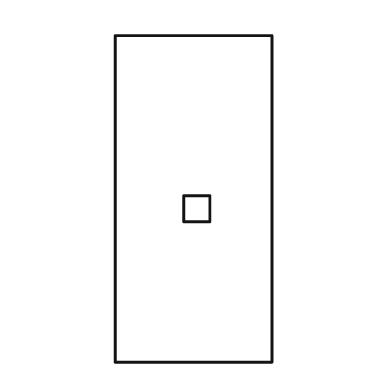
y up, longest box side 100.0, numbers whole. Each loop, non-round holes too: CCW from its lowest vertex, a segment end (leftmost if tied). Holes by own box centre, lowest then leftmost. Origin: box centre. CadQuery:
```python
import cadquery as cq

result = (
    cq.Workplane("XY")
    .moveTo(-24.0, -50.0)
    .lineTo(24.0, -50.0)
    .lineTo(24.0, 50.0)
    .lineTo(-24.0, 50.0)
    .close()
    .moveTo(-3.0, -7.0)
    .lineTo(5.0, -7.0)
    .lineTo(5.0, 1.0)
    .lineTo(-3.0, 1.0)
    .close()
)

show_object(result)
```